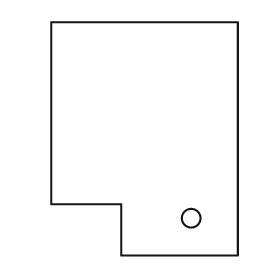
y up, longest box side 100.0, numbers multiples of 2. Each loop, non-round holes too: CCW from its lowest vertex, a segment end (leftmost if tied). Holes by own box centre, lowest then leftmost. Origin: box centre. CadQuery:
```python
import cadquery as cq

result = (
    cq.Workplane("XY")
    .moveTo(-10.0, -50.0)
    .lineTo(40.0, -50.0)
    .lineTo(40.0, 50.0)
    .lineTo(-40.0, 50.0)
    .lineTo(-40.0, -28.0)
    .lineTo(-10.0, -28.0)
    .close()
    .moveTo(20.0, -34.0)
    .circle(4.0)
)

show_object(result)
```